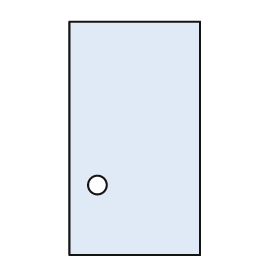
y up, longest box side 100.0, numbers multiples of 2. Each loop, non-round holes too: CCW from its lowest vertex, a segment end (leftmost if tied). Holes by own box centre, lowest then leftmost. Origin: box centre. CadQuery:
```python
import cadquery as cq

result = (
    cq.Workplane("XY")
    .moveTo(-28.0, -50.0)
    .lineTo(28.0, -50.0)
    .lineTo(28.0, 50.0)
    .lineTo(-28.0, 50.0)
    .close()
    .moveTo(-16.0, -20.0)
    .circle(4.0)
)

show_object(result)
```